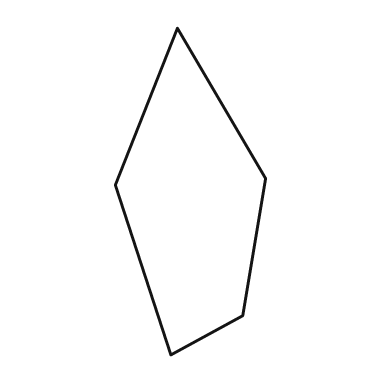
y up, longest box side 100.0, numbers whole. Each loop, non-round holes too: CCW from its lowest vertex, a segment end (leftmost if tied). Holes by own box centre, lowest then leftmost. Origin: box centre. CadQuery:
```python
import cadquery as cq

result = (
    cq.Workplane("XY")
    .moveTo(-6.0, -50.0)
    .lineTo(16.0, -38.0)
    .lineTo(23.0, 4.0)
    .lineTo(-4.0, 50.0)
    .lineTo(-23.0, 2.0)
    .close()
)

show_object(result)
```